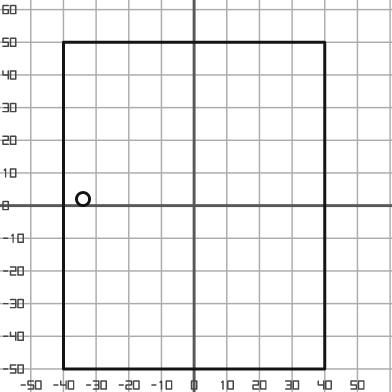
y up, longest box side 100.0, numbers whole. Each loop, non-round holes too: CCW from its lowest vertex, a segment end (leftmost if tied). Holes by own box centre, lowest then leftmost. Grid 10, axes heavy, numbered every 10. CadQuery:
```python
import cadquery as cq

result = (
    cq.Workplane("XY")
    .moveTo(-40.0, -50.0)
    .lineTo(40.0, -50.0)
    .lineTo(40.0, 50.0)
    .lineTo(-40.0, 50.0)
    .close()
    .moveTo(-34.0, 2.0)
    .circle(2.0)
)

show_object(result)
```